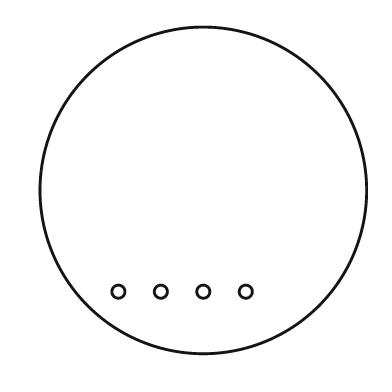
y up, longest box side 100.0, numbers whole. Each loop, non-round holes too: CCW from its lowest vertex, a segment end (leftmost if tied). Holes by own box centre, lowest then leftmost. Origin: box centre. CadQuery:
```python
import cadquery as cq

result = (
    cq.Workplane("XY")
    .moveTo(0.0, 0.0)
    .circle(50.0)
    .moveTo(-26.0, -31.0)
    .circle(2.0)
    .moveTo(-13.0, -31.0)
    .circle(2.0)
    .moveTo(0.0, -31.0)
    .circle(2.0)
    .moveTo(13.0, -31.0)
    .circle(2.0)
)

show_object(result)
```